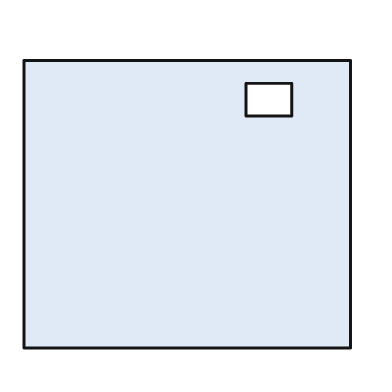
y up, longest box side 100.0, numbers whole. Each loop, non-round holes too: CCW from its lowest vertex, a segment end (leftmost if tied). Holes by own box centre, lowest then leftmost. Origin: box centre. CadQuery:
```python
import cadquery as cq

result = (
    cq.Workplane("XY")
    .moveTo(-50.0, -44.0)
    .lineTo(50.0, -44.0)
    .lineTo(50.0, 44.0)
    .lineTo(-50.0, 44.0)
    .close()
    .moveTo(18.0, 27.0)
    .lineTo(32.0, 27.0)
    .lineTo(32.0, 37.0)
    .lineTo(18.0, 37.0)
    .close()
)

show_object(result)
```